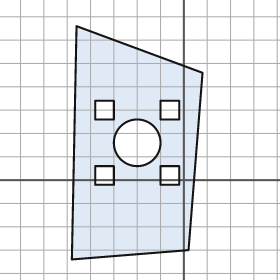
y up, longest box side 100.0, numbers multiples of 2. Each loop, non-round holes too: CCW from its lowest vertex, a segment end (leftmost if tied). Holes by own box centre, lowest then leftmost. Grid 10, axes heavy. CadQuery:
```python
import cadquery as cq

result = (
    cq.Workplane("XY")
    .moveTo(-48.0, -34.0)
    .lineTo(2.0, -30.0)
    .lineTo(8.0, 46.0)
    .lineTo(-46.0, 66.0)
    .close()
    .moveTo(-38.0, -2.0)
    .lineTo(-30.0, -2.0)
    .lineTo(-30.0, 6.0)
    .lineTo(-38.0, 6.0)
    .close()
    .moveTo(-10.0, -2.0)
    .lineTo(-2.0, -2.0)
    .lineTo(-2.0, 6.0)
    .lineTo(-10.0, 6.0)
    .close()
    .moveTo(-20.0, 16.0)
    .circle(10.0)
    .moveTo(-38.0, 26.0)
    .lineTo(-30.0, 26.0)
    .lineTo(-30.0, 34.0)
    .lineTo(-38.0, 34.0)
    .close()
    .moveTo(-10.0, 26.0)
    .lineTo(-2.0, 26.0)
    .lineTo(-2.0, 34.0)
    .lineTo(-10.0, 34.0)
    .close()
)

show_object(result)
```